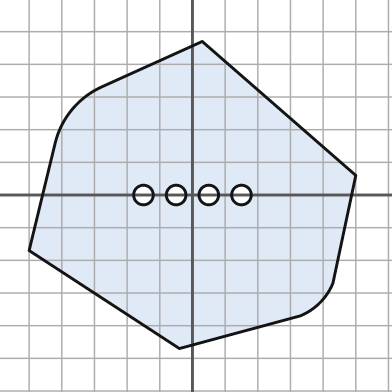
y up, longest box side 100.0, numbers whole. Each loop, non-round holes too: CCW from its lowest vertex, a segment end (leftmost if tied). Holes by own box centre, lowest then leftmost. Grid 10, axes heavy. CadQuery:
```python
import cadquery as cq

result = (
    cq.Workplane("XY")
    .moveTo(-4.0, -47.0)
    .lineTo(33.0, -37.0)
    .threePointArc((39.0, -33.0), (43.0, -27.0))
    .lineTo(50.0, 6.0)
    .lineTo(3.0, 47.0)
    .lineTo(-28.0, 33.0)
    .threePointArc((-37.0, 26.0), (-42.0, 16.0))
    .lineTo(-50.0, -17.0)
    .close()
    .moveTo(-15.0, 0.0)
    .circle(3.0)
    .moveTo(-5.0, 0.0)
    .circle(3.0)
    .moveTo(5.0, 0.0)
    .circle(3.0)
    .moveTo(15.0, 0.0)
    .circle(3.0)
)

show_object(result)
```